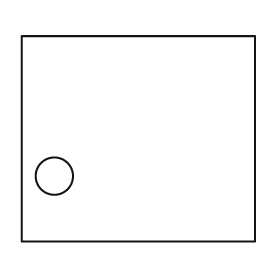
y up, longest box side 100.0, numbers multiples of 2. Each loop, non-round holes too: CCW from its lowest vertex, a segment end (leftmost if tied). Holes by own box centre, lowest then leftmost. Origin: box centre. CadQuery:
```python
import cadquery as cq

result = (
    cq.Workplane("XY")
    .moveTo(-50.0, -44.0)
    .lineTo(50.0, -44.0)
    .lineTo(50.0, 44.0)
    .lineTo(-50.0, 44.0)
    .close()
    .moveTo(-36.0, -16.0)
    .circle(8.0)
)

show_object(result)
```